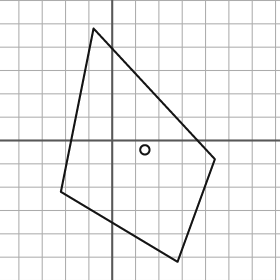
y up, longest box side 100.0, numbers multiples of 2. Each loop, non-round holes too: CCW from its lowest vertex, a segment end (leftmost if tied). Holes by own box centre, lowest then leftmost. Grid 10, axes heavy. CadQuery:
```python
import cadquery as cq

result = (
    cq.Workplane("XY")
    .moveTo(28.0, -52.0)
    .lineTo(44.0, -8.0)
    .lineTo(-8.0, 48.0)
    .lineTo(-22.0, -22.0)
    .close()
    .moveTo(14.0, -4.0)
    .circle(2.0)
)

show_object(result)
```